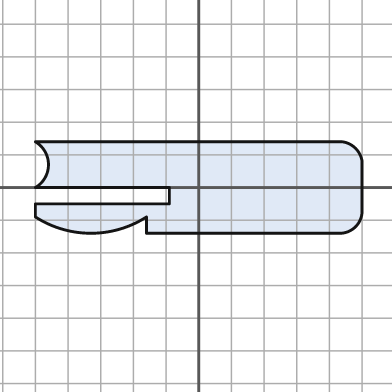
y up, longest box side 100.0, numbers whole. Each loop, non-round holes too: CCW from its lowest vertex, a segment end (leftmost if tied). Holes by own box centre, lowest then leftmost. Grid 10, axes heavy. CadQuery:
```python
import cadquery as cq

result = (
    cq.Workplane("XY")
    .moveTo(-16.0, -14.0)
    .lineTo(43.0, -14.0)
    .threePointArc((48.0, -12.0), (50.0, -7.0))
    .lineTo(50.0, 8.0)
    .threePointArc((48.0, 12.0), (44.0, 14.0))
    .lineTo(-50.0, 14.0)
    .threePointArc((-46.0, 7.0), (-50.0, 0.0))
    .lineTo(-9.0, 0.0)
    .lineTo(-9.0, -5.0)
    .lineTo(-50.0, -5.0)
    .lineTo(-50.0, -9.0)
    .threePointArc((-33.0, -14.0), (-16.0, -9.0))
    .close()
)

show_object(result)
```